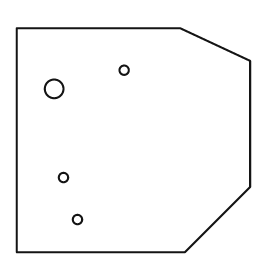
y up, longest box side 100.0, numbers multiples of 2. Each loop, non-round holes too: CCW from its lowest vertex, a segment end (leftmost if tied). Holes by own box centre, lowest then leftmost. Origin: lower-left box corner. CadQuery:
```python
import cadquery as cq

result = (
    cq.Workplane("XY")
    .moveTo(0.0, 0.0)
    .lineTo(72.0, 0.0)
    .lineTo(100.0, 28.0)
    .lineTo(100.0, 82.0)
    .lineTo(70.0, 96.0)
    .lineTo(0.0, 96.0)
    .close()
    .moveTo(26.0, 14.0)
    .circle(2.0)
    .moveTo(20.0, 32.0)
    .circle(2.0)
    .moveTo(16.0, 70.0)
    .circle(4.0)
    .moveTo(46.0, 78.0)
    .circle(2.0)
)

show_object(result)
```